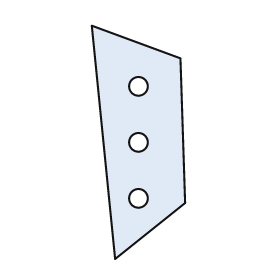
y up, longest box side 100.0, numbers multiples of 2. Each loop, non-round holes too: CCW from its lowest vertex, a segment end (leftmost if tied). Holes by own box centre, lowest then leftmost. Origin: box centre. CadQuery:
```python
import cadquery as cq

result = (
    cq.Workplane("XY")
    .moveTo(-10.0, -50.0)
    .lineTo(20.0, -26.0)
    .lineTo(18.0, 36.0)
    .lineTo(-20.0, 50.0)
    .close()
    .moveTo(0.0, -24.0)
    .circle(4.0)
    .moveTo(0.0, 0.0)
    .circle(4.0)
    .moveTo(0.0, 24.0)
    .circle(4.0)
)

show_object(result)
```